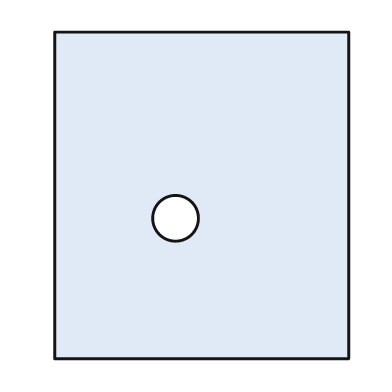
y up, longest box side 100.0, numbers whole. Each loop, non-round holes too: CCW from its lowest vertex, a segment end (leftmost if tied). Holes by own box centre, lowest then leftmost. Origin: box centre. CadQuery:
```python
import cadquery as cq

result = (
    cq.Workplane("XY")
    .moveTo(-45.0, -50.0)
    .lineTo(45.0, -50.0)
    .lineTo(45.0, 50.0)
    .lineTo(-45.0, 50.0)
    .close()
    .moveTo(-8.0, -7.0)
    .circle(7.0)
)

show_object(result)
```